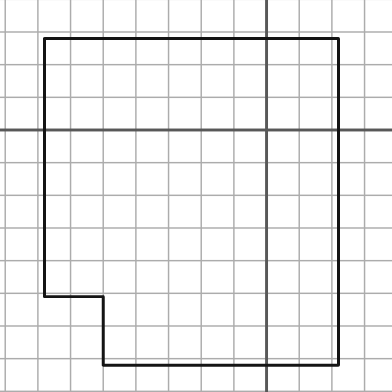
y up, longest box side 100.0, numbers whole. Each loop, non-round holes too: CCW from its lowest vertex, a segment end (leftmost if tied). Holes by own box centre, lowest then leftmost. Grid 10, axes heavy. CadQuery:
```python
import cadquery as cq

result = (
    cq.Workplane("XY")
    .moveTo(-50.0, -72.0)
    .lineTo(22.0, -72.0)
    .lineTo(22.0, 28.0)
    .lineTo(-68.0, 28.0)
    .lineTo(-68.0, -51.0)
    .lineTo(-50.0, -51.0)
    .close()
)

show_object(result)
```